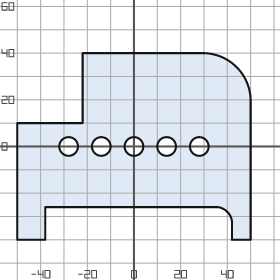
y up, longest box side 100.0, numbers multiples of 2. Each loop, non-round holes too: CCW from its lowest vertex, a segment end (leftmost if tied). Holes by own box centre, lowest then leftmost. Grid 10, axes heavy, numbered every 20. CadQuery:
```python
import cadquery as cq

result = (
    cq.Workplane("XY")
    .moveTo(-50.0, -40.0)
    .lineTo(-38.0, -40.0)
    .lineTo(-38.0, -26.0)
    .lineTo(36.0, -26.0)
    .threePointArc((40.0, -28.0), (42.0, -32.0))
    .lineTo(42.0, -40.0)
    .lineTo(50.0, -40.0)
    .lineTo(50.0, 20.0)
    .threePointArc((44.0, 34.0), (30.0, 40.0))
    .lineTo(-22.0, 40.0)
    .lineTo(-22.0, 10.0)
    .lineTo(-50.0, 10.0)
    .close()
    .moveTo(-28.0, 0.0)
    .circle(4.0)
    .moveTo(-14.0, 0.0)
    .circle(4.0)
    .moveTo(0.0, 0.0)
    .circle(4.0)
    .moveTo(14.0, 0.0)
    .circle(4.0)
    .moveTo(28.0, 0.0)
    .circle(4.0)
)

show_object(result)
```